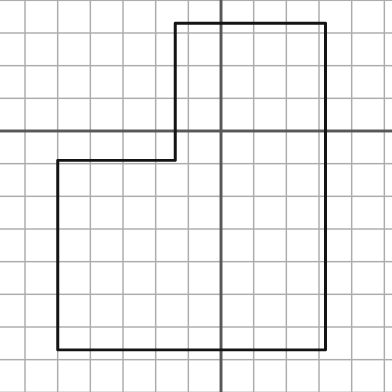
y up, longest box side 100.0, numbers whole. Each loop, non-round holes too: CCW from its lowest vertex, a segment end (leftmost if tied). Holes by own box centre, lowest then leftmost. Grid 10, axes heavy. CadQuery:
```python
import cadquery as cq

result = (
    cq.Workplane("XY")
    .moveTo(-50.0, -67.0)
    .lineTo(32.0, -67.0)
    .lineTo(32.0, 33.0)
    .lineTo(-14.0, 33.0)
    .lineTo(-14.0, -9.0)
    .lineTo(-50.0, -9.0)
    .close()
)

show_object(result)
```